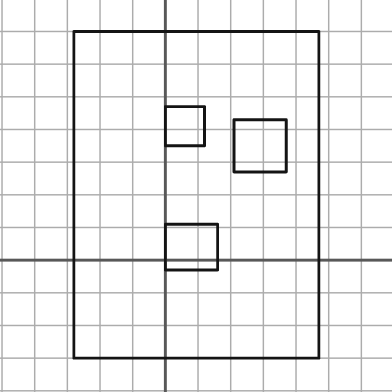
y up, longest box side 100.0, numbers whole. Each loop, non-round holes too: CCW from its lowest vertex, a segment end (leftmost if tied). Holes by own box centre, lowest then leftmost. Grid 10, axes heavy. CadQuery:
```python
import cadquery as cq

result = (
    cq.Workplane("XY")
    .moveTo(-28.0, -30.0)
    .lineTo(47.0, -30.0)
    .lineTo(47.0, 70.0)
    .lineTo(-28.0, 70.0)
    .close()
    .moveTo(0.0, -3.0)
    .lineTo(16.0, -3.0)
    .lineTo(16.0, 11.0)
    .lineTo(0.0, 11.0)
    .close()
    .moveTo(21.0, 27.0)
    .lineTo(37.0, 27.0)
    .lineTo(37.0, 43.0)
    .lineTo(21.0, 43.0)
    .close()
    .moveTo(0.0, 35.0)
    .lineTo(12.0, 35.0)
    .lineTo(12.0, 47.0)
    .lineTo(0.0, 47.0)
    .close()
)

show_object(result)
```